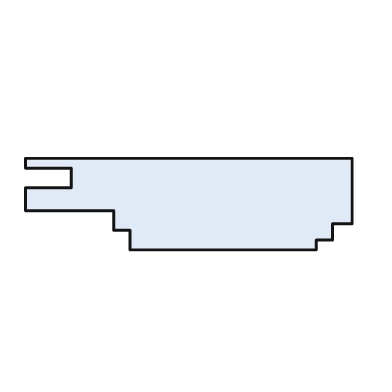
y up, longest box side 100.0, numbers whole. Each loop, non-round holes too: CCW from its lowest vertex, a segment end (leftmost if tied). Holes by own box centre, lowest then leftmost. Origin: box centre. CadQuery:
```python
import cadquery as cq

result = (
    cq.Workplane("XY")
    .moveTo(-18.0, -14.0)
    .lineTo(39.0, -14.0)
    .lineTo(39.0, -11.0)
    .lineTo(44.0, -11.0)
    .lineTo(44.0, -6.0)
    .lineTo(50.0, -6.0)
    .lineTo(50.0, 14.0)
    .lineTo(-50.0, 14.0)
    .lineTo(-50.0, 11.0)
    .lineTo(-36.0, 11.0)
    .lineTo(-36.0, 5.0)
    .lineTo(-50.0, 5.0)
    .lineTo(-50.0, -2.0)
    .lineTo(-23.0, -2.0)
    .lineTo(-23.0, -8.0)
    .lineTo(-18.0, -8.0)
    .close()
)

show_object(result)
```